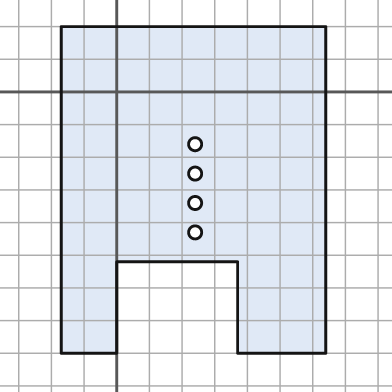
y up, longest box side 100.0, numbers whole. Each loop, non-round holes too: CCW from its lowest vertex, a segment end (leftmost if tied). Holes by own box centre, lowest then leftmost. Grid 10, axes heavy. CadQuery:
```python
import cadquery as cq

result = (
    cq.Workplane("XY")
    .moveTo(-17.0, -80.0)
    .lineTo(0.0, -80.0)
    .lineTo(0.0, -52.0)
    .lineTo(37.0, -52.0)
    .lineTo(37.0, -80.0)
    .lineTo(64.0, -80.0)
    .lineTo(64.0, 20.0)
    .lineTo(-17.0, 20.0)
    .close()
    .moveTo(24.0, -43.0)
    .circle(2.0)
    .moveTo(24.0, -34.0)
    .circle(2.0)
    .moveTo(24.0, -25.0)
    .circle(2.0)
    .moveTo(24.0, -16.0)
    .circle(2.0)
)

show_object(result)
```